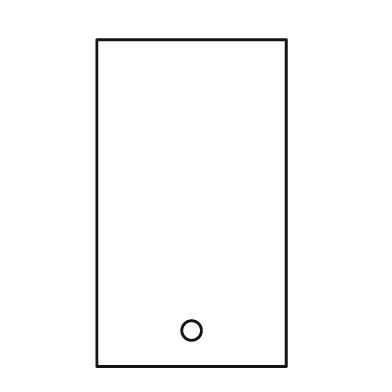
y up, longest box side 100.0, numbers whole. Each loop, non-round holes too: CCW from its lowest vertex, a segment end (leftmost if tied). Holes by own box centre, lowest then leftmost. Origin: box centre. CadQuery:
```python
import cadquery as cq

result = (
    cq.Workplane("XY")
    .moveTo(-29.0, -50.0)
    .lineTo(29.0, -50.0)
    .lineTo(29.0, 50.0)
    .lineTo(-29.0, 50.0)
    .close()
    .moveTo(0.0, -39.0)
    .circle(3.0)
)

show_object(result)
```